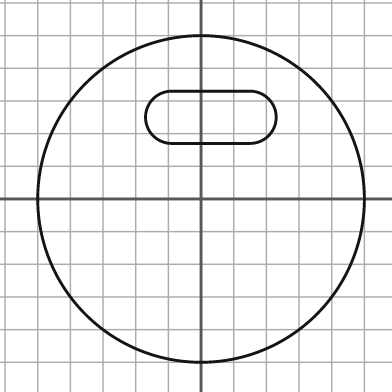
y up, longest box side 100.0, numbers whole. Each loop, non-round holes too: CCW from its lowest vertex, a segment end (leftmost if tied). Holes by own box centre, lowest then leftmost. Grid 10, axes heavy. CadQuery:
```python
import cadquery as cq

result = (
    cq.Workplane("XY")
    .moveTo(0.0, 0.0)
    .circle(50.0)
    .moveTo(-9.0, 17.0)
    .lineTo(15.0, 17.0)
    .threePointArc((23.0, 25.0), (15.0, 33.0))
    .lineTo(-9.0, 33.0)
    .threePointArc((-17.0, 25.0), (-9.0, 17.0))
    .close()
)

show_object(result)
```